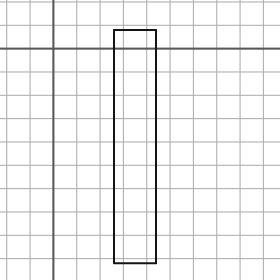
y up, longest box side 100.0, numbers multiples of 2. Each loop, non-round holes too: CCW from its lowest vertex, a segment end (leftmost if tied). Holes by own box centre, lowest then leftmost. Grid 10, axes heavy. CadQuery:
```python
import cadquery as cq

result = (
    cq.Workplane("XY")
    .moveTo(26.0, -92.0)
    .lineTo(44.0, -92.0)
    .lineTo(44.0, 8.0)
    .lineTo(26.0, 8.0)
    .close()
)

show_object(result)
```